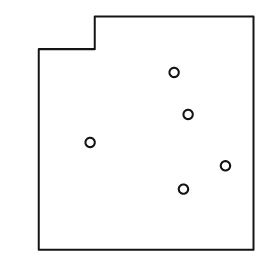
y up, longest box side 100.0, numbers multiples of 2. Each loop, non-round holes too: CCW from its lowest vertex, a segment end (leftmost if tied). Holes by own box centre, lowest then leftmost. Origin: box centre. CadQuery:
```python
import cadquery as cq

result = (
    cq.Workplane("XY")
    .moveTo(-46.0, -50.0)
    .lineTo(46.0, -50.0)
    .lineTo(46.0, 50.0)
    .lineTo(-22.0, 50.0)
    .lineTo(-22.0, 36.0)
    .lineTo(-46.0, 36.0)
    .close()
    .moveTo(16.0, -24.0)
    .circle(2.0)
    .moveTo(34.0, -14.0)
    .circle(2.0)
    .moveTo(-24.0, -4.0)
    .circle(2.0)
    .moveTo(18.0, 8.0)
    .circle(2.0)
    .moveTo(12.0, 26.0)
    .circle(2.0)
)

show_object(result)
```